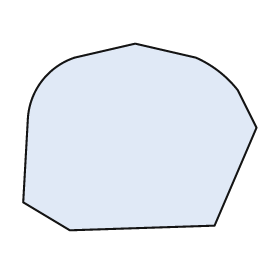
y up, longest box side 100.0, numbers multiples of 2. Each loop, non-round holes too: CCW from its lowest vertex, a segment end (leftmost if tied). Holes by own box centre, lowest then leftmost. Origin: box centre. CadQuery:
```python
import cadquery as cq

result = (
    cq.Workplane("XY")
    .moveTo(-30.0, -40.0)
    .lineTo(32.0, -38.0)
    .lineTo(50.0, 4.0)
    .lineTo(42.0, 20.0)
    .threePointArc((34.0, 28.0), (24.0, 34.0))
    .lineTo(-2.0, 40.0)
    .lineTo(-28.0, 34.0)
    .threePointArc((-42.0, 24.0), (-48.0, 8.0))
    .lineTo(-50.0, -28.0)
    .close()
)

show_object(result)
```